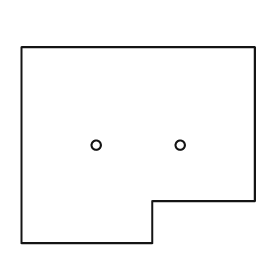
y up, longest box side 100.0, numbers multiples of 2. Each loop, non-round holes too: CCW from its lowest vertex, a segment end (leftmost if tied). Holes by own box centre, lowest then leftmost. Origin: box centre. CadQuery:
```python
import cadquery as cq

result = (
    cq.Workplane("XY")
    .moveTo(-50.0, -42.0)
    .lineTo(6.0, -42.0)
    .lineTo(6.0, -24.0)
    .lineTo(50.0, -24.0)
    .lineTo(50.0, 42.0)
    .lineTo(-50.0, 42.0)
    .close()
    .moveTo(-18.0, 0.0)
    .circle(2.0)
    .moveTo(18.0, 0.0)
    .circle(2.0)
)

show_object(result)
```